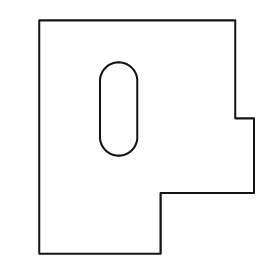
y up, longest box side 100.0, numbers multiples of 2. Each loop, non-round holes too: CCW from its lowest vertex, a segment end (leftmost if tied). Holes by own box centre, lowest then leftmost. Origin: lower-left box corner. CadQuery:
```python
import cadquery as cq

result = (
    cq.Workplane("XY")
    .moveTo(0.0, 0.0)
    .lineTo(52.0, 0.0)
    .lineTo(52.0, 26.0)
    .lineTo(92.0, 26.0)
    .lineTo(92.0, 58.0)
    .lineTo(84.0, 58.0)
    .lineTo(84.0, 100.0)
    .lineTo(0.0, 100.0)
    .close()
    .moveTo(26.0, 50.0)
    .threePointArc((34.0, 42.0), (42.0, 50.0))
    .lineTo(42.0, 74.0)
    .threePointArc((34.0, 82.0), (26.0, 74.0))
    .close()
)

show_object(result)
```